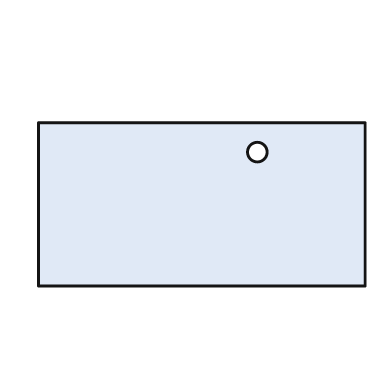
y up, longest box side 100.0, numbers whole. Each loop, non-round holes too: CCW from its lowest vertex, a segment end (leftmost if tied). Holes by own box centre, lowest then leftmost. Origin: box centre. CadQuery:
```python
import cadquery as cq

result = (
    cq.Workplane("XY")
    .moveTo(-50.0, -25.0)
    .lineTo(50.0, -25.0)
    .lineTo(50.0, 25.0)
    .lineTo(-50.0, 25.0)
    .close()
    .moveTo(17.0, 16.0)
    .circle(3.0)
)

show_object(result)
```